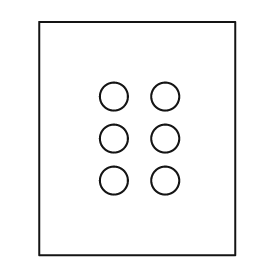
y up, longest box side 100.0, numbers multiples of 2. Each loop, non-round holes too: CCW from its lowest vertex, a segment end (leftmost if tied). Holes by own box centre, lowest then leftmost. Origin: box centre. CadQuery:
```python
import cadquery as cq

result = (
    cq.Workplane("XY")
    .moveTo(-42.0, -50.0)
    .lineTo(42.0, -50.0)
    .lineTo(42.0, 50.0)
    .lineTo(-42.0, 50.0)
    .close()
    .moveTo(-10.0, -18.0)
    .circle(6.0)
    .moveTo(12.0, -18.0)
    .circle(6.0)
    .moveTo(-10.0, 0.0)
    .circle(6.0)
    .moveTo(12.0, 0.0)
    .circle(6.0)
    .moveTo(-10.0, 18.0)
    .circle(6.0)
    .moveTo(12.0, 18.0)
    .circle(6.0)
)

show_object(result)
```